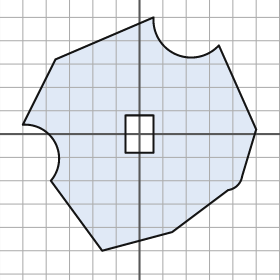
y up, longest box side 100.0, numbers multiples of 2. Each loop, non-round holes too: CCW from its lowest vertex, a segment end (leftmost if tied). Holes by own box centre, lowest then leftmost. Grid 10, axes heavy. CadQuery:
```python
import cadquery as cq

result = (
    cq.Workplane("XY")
    .moveTo(-16.0, -50.0)
    .lineTo(14.0, -42.0)
    .lineTo(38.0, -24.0)
    .threePointArc((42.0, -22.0), (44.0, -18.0))
    .lineTo(50.0, 2.0)
    .lineTo(34.0, 38.0)
    .threePointArc((16.0, 34.0), (6.0, 50.0))
    .lineTo(-36.0, 32.0)
    .lineTo(-50.0, 4.0)
    .threePointArc((-36.0, -4.0), (-38.0, -20.0))
    .close()
    .moveTo(-6.0, -8.0)
    .lineTo(6.0, -8.0)
    .lineTo(6.0, 8.0)
    .lineTo(-6.0, 8.0)
    .close()
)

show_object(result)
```